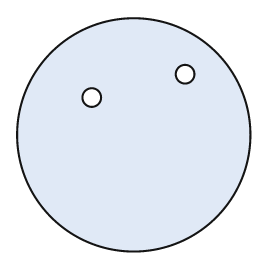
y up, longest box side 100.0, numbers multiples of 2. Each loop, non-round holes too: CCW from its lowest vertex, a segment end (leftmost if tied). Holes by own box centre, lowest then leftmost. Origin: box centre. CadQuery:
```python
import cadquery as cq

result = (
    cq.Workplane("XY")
    .moveTo(0.0, 0.0)
    .circle(50.0)
    .moveTo(-18.0, 16.0)
    .circle(4.0)
    .moveTo(22.0, 26.0)
    .circle(4.0)
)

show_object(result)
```